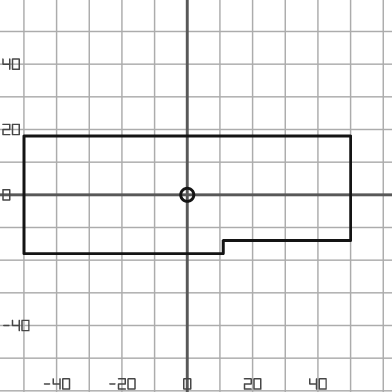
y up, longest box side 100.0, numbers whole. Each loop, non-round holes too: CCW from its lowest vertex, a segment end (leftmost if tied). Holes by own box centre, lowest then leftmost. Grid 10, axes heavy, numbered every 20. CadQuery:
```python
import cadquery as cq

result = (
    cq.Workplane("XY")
    .moveTo(-50.0, -18.0)
    .lineTo(11.0, -18.0)
    .lineTo(11.0, -14.0)
    .lineTo(50.0, -14.0)
    .lineTo(50.0, 18.0)
    .lineTo(-50.0, 18.0)
    .close()
    .moveTo(0.0, 0.0)
    .circle(2.0)
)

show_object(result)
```